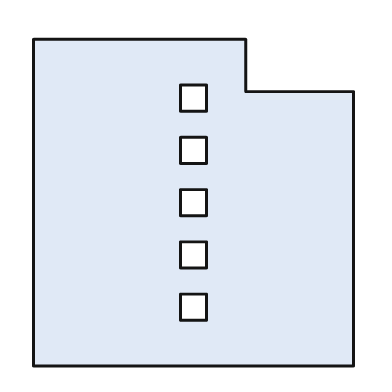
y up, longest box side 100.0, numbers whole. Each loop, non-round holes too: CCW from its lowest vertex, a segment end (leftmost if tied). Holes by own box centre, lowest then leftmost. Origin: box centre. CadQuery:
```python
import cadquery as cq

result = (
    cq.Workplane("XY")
    .moveTo(-49.0, -50.0)
    .lineTo(49.0, -50.0)
    .lineTo(49.0, 34.0)
    .lineTo(16.0, 34.0)
    .lineTo(16.0, 50.0)
    .lineTo(-49.0, 50.0)
    .close()
    .moveTo(-4.0, -36.0)
    .lineTo(4.0, -36.0)
    .lineTo(4.0, -28.0)
    .lineTo(-4.0, -28.0)
    .close()
    .moveTo(-4.0, -20.0)
    .lineTo(4.0, -20.0)
    .lineTo(4.0, -12.0)
    .lineTo(-4.0, -12.0)
    .close()
    .moveTo(-4.0, -4.0)
    .lineTo(4.0, -4.0)
    .lineTo(4.0, 4.0)
    .lineTo(-4.0, 4.0)
    .close()
    .moveTo(-4.0, 12.0)
    .lineTo(4.0, 12.0)
    .lineTo(4.0, 20.0)
    .lineTo(-4.0, 20.0)
    .close()
    .moveTo(-4.0, 28.0)
    .lineTo(4.0, 28.0)
    .lineTo(4.0, 36.0)
    .lineTo(-4.0, 36.0)
    .close()
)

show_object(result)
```